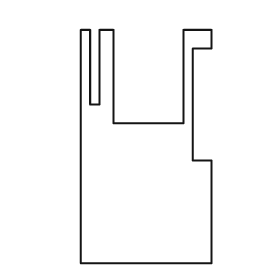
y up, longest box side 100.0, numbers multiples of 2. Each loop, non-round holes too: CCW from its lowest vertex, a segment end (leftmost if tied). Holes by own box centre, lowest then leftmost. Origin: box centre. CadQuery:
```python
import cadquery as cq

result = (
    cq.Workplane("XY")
    .moveTo(-28.0, -50.0)
    .lineTo(28.0, -50.0)
    .lineTo(28.0, -6.0)
    .lineTo(20.0, -6.0)
    .lineTo(20.0, 42.0)
    .lineTo(28.0, 42.0)
    .lineTo(28.0, 50.0)
    .lineTo(16.0, 50.0)
    .lineTo(16.0, 10.0)
    .lineTo(-14.0, 10.0)
    .lineTo(-14.0, 50.0)
    .lineTo(-20.0, 50.0)
    .lineTo(-20.0, 18.0)
    .lineTo(-24.0, 18.0)
    .lineTo(-24.0, 50.0)
    .lineTo(-28.0, 50.0)
    .close()
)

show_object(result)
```